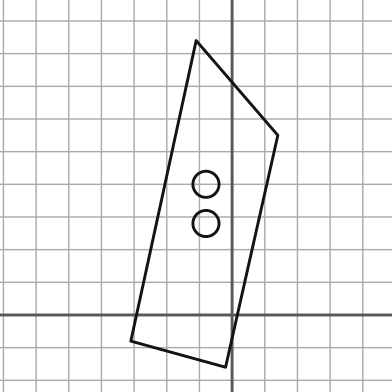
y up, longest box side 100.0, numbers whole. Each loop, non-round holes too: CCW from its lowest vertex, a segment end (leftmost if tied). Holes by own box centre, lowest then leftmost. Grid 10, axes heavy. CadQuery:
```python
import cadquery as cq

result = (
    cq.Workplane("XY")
    .moveTo(-2.0, -16.0)
    .lineTo(14.0, 55.0)
    .lineTo(-11.0, 84.0)
    .lineTo(-31.0, -8.0)
    .close()
    .moveTo(-8.0, 28.0)
    .circle(4.0)
    .moveTo(-8.0, 40.0)
    .circle(4.0)
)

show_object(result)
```